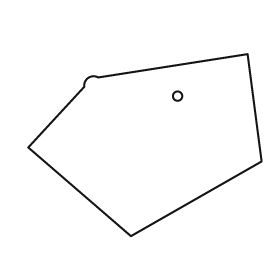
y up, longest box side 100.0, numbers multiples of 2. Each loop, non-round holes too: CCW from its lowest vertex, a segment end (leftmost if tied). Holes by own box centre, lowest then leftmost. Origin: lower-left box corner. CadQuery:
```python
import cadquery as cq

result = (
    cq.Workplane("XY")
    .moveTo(44.0, 0.0)
    .lineTo(100.0, 32.0)
    .lineTo(94.0, 78.0)
    .lineTo(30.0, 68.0)
    .threePointArc((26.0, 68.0), (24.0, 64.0))
    .lineTo(0.0, 38.0)
    .close()
    .moveTo(64.0, 60.0)
    .circle(2.0)
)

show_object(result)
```